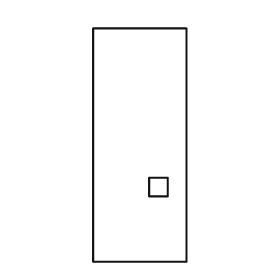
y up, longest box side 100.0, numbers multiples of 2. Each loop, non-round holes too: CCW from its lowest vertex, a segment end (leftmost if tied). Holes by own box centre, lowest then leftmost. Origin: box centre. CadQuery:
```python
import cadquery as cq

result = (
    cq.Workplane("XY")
    .moveTo(-20.0, -50.0)
    .lineTo(20.0, -50.0)
    .lineTo(20.0, 50.0)
    .lineTo(-20.0, 50.0)
    .close()
    .moveTo(4.0, -22.0)
    .lineTo(12.0, -22.0)
    .lineTo(12.0, -14.0)
    .lineTo(4.0, -14.0)
    .close()
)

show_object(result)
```